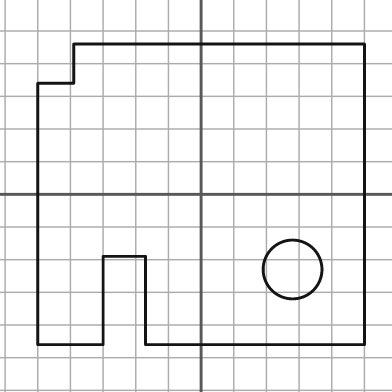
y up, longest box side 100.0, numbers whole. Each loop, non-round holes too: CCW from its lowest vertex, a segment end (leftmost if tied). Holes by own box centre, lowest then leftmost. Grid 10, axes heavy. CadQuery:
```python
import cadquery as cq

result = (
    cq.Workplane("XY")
    .moveTo(-50.0, -46.0)
    .lineTo(-30.0, -46.0)
    .lineTo(-30.0, -19.0)
    .lineTo(-17.0, -19.0)
    .lineTo(-17.0, -46.0)
    .lineTo(50.0, -46.0)
    .lineTo(50.0, 46.0)
    .lineTo(-39.0, 46.0)
    .lineTo(-39.0, 34.0)
    .lineTo(-50.0, 34.0)
    .close()
    .moveTo(28.0, -23.0)
    .circle(9.0)
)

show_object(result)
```